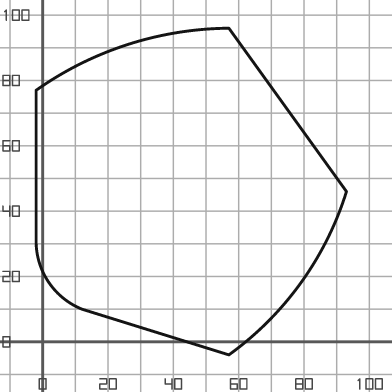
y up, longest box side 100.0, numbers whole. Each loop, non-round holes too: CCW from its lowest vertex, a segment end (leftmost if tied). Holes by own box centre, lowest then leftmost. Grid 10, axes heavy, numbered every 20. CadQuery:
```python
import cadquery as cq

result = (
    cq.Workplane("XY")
    .moveTo(57.0, -4.0)
    .threePointArc((79.0, 18.0), (93.0, 46.0))
    .lineTo(57.0, 96.0)
    .threePointArc((26.0, 91.0), (-2.0, 77.0))
    .lineTo(-2.0, 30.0)
    .threePointArc((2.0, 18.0), (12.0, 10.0))
    .close()
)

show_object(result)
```